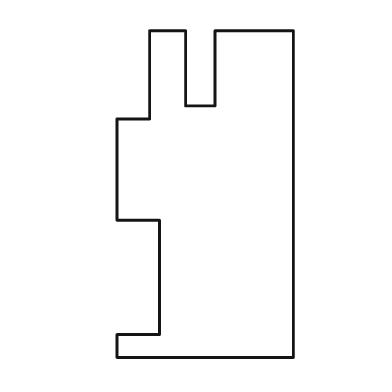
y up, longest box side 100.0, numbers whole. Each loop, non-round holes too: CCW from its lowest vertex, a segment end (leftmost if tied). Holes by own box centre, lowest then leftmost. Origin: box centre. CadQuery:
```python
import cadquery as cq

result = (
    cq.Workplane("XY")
    .moveTo(-27.0, -50.0)
    .lineTo(27.0, -50.0)
    .lineTo(27.0, 50.0)
    .lineTo(3.0, 50.0)
    .lineTo(3.0, 27.0)
    .lineTo(-6.0, 27.0)
    .lineTo(-6.0, 50.0)
    .lineTo(-17.0, 50.0)
    .lineTo(-17.0, 23.0)
    .lineTo(-27.0, 23.0)
    .lineTo(-27.0, -8.0)
    .lineTo(-14.0, -8.0)
    .lineTo(-14.0, -43.0)
    .lineTo(-27.0, -43.0)
    .close()
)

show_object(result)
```